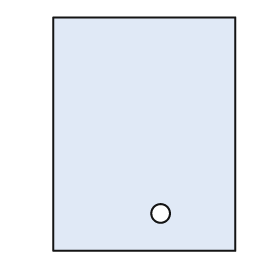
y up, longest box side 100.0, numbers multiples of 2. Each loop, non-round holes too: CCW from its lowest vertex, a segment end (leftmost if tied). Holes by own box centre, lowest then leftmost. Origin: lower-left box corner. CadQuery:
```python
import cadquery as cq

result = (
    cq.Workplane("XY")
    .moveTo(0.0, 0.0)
    .lineTo(78.0, 0.0)
    .lineTo(78.0, 100.0)
    .lineTo(0.0, 100.0)
    .close()
    .moveTo(46.0, 16.0)
    .circle(4.0)
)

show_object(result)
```